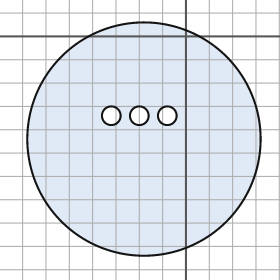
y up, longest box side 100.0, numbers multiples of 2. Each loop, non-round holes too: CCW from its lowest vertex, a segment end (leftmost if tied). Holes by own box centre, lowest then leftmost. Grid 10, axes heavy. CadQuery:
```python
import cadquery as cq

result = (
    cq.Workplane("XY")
    .moveTo(-18.0, -44.0)
    .circle(50.0)
    .moveTo(-32.0, -34.0)
    .circle(4.0)
    .moveTo(-20.0, -34.0)
    .circle(4.0)
    .moveTo(-8.0, -34.0)
    .circle(4.0)
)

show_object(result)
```